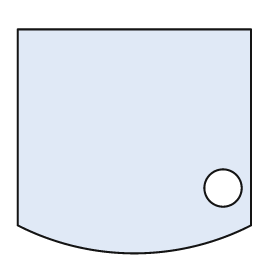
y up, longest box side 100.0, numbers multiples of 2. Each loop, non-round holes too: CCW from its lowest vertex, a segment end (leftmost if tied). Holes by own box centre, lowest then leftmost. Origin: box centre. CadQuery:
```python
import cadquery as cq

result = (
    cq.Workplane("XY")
    .moveTo(-50.0, -36.0)
    .threePointArc((0.0, -48.0), (50.0, -36.0))
    .lineTo(50.0, 48.0)
    .lineTo(-50.0, 48.0)
    .close()
    .moveTo(38.0, -20.0)
    .circle(8.0)
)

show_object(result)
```